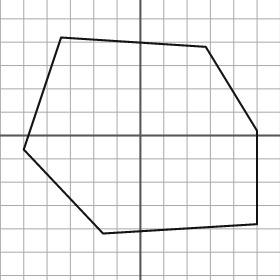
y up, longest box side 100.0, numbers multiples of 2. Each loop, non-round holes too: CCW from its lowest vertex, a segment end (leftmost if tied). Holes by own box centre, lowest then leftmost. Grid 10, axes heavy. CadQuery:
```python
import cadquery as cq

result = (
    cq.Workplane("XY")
    .moveTo(-16.0, -42.0)
    .lineTo(50.0, -38.0)
    .lineTo(50.0, 2.0)
    .lineTo(28.0, 38.0)
    .lineTo(-34.0, 42.0)
    .lineTo(-50.0, -6.0)
    .close()
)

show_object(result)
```